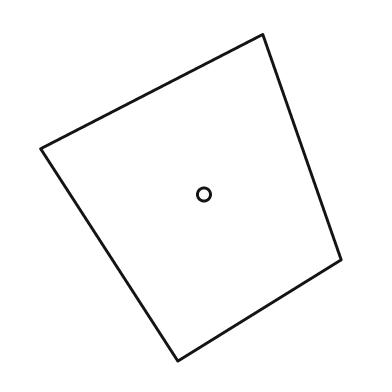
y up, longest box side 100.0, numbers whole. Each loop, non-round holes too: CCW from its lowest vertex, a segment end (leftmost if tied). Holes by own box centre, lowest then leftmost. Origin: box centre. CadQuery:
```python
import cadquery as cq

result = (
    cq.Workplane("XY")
    .moveTo(-4.0, -50.0)
    .lineTo(46.0, -19.0)
    .lineTo(22.0, 50.0)
    .lineTo(-46.0, 15.0)
    .close()
    .moveTo(4.0, 1.0)
    .circle(2.0)
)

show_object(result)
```